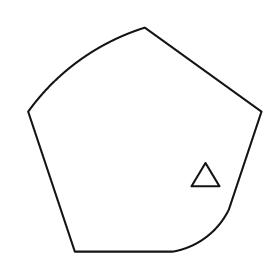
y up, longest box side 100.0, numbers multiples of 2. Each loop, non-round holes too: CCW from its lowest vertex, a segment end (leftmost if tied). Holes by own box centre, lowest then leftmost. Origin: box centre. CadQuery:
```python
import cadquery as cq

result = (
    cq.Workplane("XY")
    .moveTo(-30.0, -48.0)
    .lineTo(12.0, -48.0)
    .threePointArc((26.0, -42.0), (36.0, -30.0))
    .lineTo(50.0, 12.0)
    .lineTo(0.0, 48.0)
    .threePointArc((-28.0, 34.0), (-50.0, 12.0))
    .close()
    .moveTo(20.0, -20.0)
    .lineTo(32.0, -20.0)
    .lineTo(26.0, -10.0)
    .close()
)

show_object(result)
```